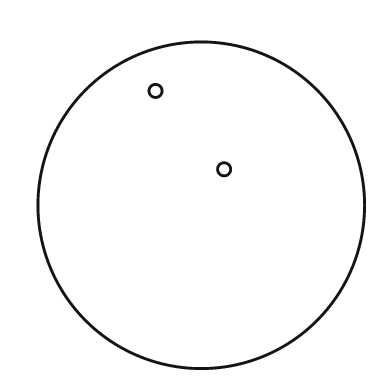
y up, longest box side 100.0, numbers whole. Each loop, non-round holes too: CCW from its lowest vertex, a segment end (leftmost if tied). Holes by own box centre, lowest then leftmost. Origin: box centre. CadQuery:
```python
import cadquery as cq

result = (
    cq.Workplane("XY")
    .moveTo(0.0, 0.0)
    .circle(50.0)
    .moveTo(7.0, 11.0)
    .circle(2.0)
    .moveTo(-14.0, 35.0)
    .circle(2.0)
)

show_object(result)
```